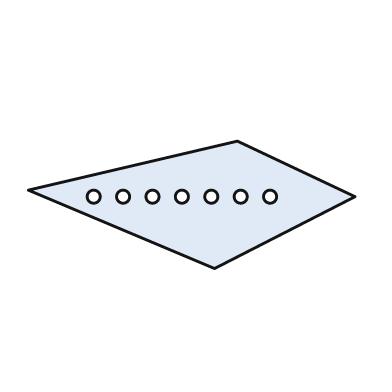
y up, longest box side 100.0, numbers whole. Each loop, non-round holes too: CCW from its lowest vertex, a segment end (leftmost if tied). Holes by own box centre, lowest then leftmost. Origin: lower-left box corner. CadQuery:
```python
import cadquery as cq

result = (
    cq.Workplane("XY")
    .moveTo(57.0, 0.0)
    .lineTo(100.0, 22.0)
    .lineTo(64.0, 39.0)
    .lineTo(0.0, 24.0)
    .close()
    .moveTo(20.0, 22.0)
    .circle(2.0)
    .moveTo(29.0, 22.0)
    .circle(2.0)
    .moveTo(38.0, 22.0)
    .circle(2.0)
    .moveTo(47.0, 22.0)
    .circle(2.0)
    .moveTo(56.0, 22.0)
    .circle(2.0)
    .moveTo(65.0, 22.0)
    .circle(2.0)
    .moveTo(74.0, 22.0)
    .circle(2.0)
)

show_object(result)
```